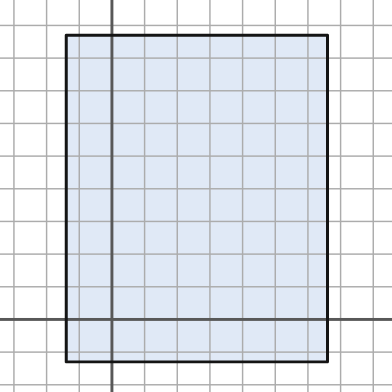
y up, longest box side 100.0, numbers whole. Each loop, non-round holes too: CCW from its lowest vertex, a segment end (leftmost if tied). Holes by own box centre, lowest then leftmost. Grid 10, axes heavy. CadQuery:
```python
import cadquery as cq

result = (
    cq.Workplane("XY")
    .moveTo(-14.0, -13.0)
    .lineTo(66.0, -13.0)
    .lineTo(66.0, 87.0)
    .lineTo(-14.0, 87.0)
    .close()
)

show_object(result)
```